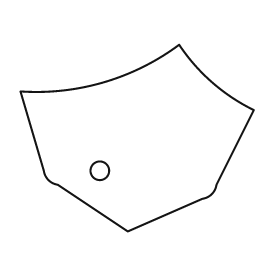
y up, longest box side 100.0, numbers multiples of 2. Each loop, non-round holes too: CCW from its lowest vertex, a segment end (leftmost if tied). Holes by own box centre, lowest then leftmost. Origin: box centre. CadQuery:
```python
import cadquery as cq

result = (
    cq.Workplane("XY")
    .moveTo(-4.0, -40.0)
    .lineTo(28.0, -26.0)
    .threePointArc((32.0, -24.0), (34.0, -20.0))
    .lineTo(50.0, 12.0)
    .threePointArc((32.0, 24.0), (18.0, 40.0))
    .threePointArc((-14.0, 24.0), (-50.0, 20.0))
    .lineTo(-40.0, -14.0)
    .threePointArc((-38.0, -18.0), (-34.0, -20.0))
    .close()
    .moveTo(-16.0, -14.0)
    .circle(4.0)
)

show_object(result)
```